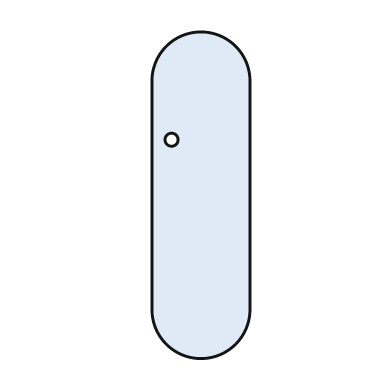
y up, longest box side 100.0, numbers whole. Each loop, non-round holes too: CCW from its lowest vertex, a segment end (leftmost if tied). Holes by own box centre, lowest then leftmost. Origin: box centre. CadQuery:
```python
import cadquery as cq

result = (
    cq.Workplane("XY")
    .moveTo(-15.0, -35.0)
    .threePointArc((0.0, -50.0), (15.0, -35.0))
    .lineTo(15.0, 35.0)
    .threePointArc((0.0, 50.0), (-15.0, 35.0))
    .close()
    .moveTo(-9.0, 17.0)
    .circle(2.0)
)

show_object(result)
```